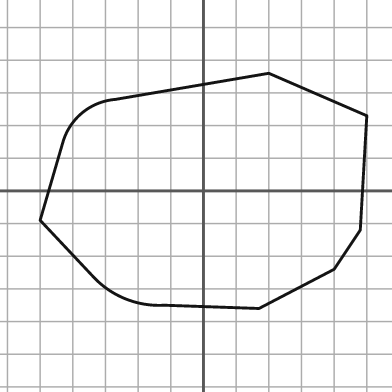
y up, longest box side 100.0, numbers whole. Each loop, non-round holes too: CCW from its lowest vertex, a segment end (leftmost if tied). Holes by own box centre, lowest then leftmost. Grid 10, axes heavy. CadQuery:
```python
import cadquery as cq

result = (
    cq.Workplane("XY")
    .moveTo(17.0, -36.0)
    .lineTo(40.0, -24.0)
    .lineTo(48.0, -12.0)
    .lineTo(50.0, 23.0)
    .lineTo(20.0, 36.0)
    .lineTo(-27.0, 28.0)
    .threePointArc((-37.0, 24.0), (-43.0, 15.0))
    .lineTo(-50.0, -9.0)
    .lineTo(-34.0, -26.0)
    .threePointArc((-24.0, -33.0), (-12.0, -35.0))
    .close()
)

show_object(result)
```